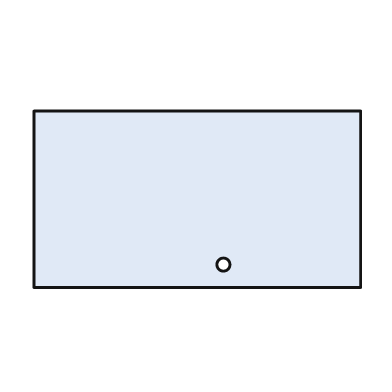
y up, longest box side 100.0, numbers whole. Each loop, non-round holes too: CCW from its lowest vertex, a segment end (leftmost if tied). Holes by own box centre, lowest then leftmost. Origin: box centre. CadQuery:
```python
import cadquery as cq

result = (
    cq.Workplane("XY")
    .moveTo(-50.0, -27.0)
    .lineTo(50.0, -27.0)
    .lineTo(50.0, 27.0)
    .lineTo(-50.0, 27.0)
    .close()
    .moveTo(8.0, -20.0)
    .circle(2.0)
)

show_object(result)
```